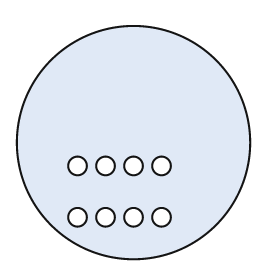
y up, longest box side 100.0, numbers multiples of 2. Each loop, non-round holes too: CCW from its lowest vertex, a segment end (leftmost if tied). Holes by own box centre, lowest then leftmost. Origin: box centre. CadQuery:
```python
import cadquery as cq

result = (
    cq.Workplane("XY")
    .moveTo(0.0, 0.0)
    .circle(50.0)
    .moveTo(-24.0, -32.0)
    .circle(4.0)
    .moveTo(-12.0, -32.0)
    .circle(4.0)
    .moveTo(0.0, -32.0)
    .circle(4.0)
    .moveTo(12.0, -32.0)
    .circle(4.0)
    .moveTo(-24.0, -10.0)
    .circle(4.0)
    .moveTo(-12.0, -10.0)
    .circle(4.0)
    .moveTo(0.0, -10.0)
    .circle(4.0)
    .moveTo(12.0, -10.0)
    .circle(4.0)
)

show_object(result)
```